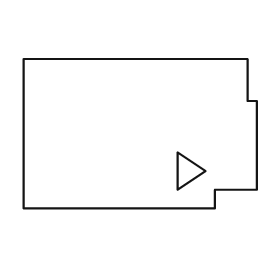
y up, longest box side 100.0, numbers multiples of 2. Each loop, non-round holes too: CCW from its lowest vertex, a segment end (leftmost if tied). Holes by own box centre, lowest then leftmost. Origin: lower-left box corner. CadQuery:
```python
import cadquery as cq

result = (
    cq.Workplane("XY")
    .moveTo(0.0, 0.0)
    .lineTo(82.0, 0.0)
    .lineTo(82.0, 8.0)
    .lineTo(100.0, 8.0)
    .lineTo(100.0, 46.0)
    .lineTo(96.0, 46.0)
    .lineTo(96.0, 64.0)
    .lineTo(0.0, 64.0)
    .close()
    .moveTo(66.0, 8.0)
    .lineTo(78.0, 16.0)
    .lineTo(66.0, 24.0)
    .close()
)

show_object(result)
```